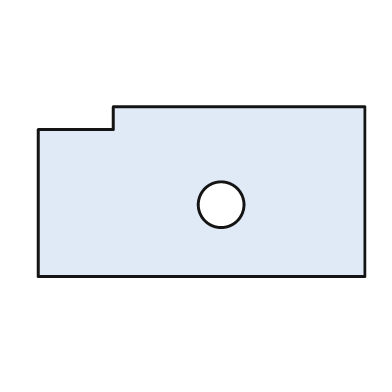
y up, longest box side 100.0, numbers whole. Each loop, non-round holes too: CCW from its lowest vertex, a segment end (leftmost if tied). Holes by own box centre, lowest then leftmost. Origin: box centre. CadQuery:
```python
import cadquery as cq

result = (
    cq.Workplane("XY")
    .moveTo(-50.0, -26.0)
    .lineTo(50.0, -26.0)
    .lineTo(50.0, 26.0)
    .lineTo(-27.0, 26.0)
    .lineTo(-27.0, 19.0)
    .lineTo(-50.0, 19.0)
    .close()
    .moveTo(6.0, -4.0)
    .circle(7.0)
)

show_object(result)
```